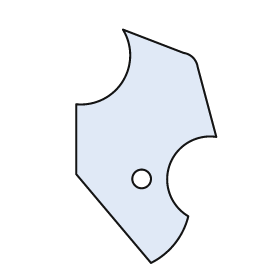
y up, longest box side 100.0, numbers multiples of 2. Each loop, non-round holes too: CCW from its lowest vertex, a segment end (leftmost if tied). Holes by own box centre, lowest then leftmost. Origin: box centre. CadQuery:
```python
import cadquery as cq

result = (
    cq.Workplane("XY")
    .moveTo(2.0, -50.0)
    .threePointArc((12.0, -42.0), (18.0, -30.0))
    .threePointArc((10.0, -8.0), (30.0, 4.0))
    .lineTo(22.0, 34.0)
    .threePointArc((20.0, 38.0), (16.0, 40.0))
    .lineTo(-10.0, 50.0)
    .threePointArc((-10.0, 28.0), (-30.0, 18.0))
    .lineTo(-30.0, -12.0)
    .close()
    .moveTo(-2.0, -14.0)
    .circle(4.0)
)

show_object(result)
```